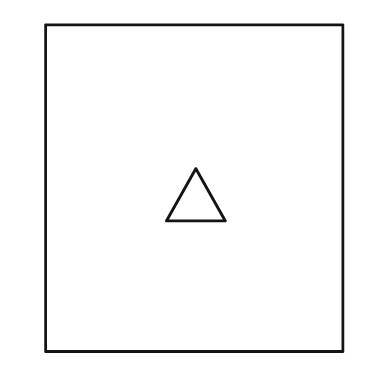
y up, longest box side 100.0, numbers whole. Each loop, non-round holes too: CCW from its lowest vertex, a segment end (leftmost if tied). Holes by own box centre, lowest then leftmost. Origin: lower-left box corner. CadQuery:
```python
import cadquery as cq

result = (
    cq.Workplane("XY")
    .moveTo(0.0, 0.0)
    .lineTo(91.0, 0.0)
    .lineTo(91.0, 100.0)
    .lineTo(0.0, 100.0)
    .close()
    .moveTo(37.0, 40.0)
    .lineTo(55.0, 40.0)
    .lineTo(46.0, 56.0)
    .close()
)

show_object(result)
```